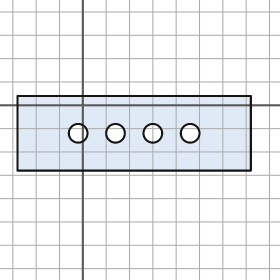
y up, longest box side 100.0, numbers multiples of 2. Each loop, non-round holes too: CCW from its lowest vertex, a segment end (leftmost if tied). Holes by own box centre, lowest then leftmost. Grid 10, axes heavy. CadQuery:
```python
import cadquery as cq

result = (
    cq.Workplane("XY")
    .moveTo(-28.0, -28.0)
    .lineTo(72.0, -28.0)
    .lineTo(72.0, 4.0)
    .lineTo(-28.0, 4.0)
    .close()
    .moveTo(-2.0, -12.0)
    .circle(4.0)
    .moveTo(14.0, -12.0)
    .circle(4.0)
    .moveTo(30.0, -12.0)
    .circle(4.0)
    .moveTo(46.0, -12.0)
    .circle(4.0)
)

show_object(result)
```